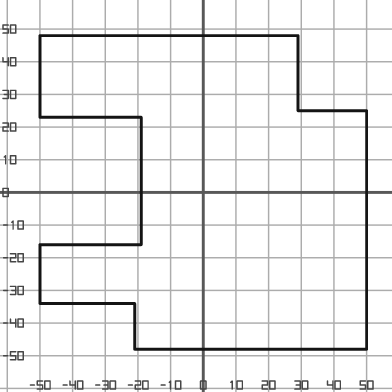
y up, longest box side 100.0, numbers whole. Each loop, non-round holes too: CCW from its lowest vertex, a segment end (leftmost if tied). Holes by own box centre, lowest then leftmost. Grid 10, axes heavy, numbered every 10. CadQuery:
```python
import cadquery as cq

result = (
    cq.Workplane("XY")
    .moveTo(-21.0, -48.0)
    .lineTo(50.0, -48.0)
    .lineTo(50.0, 25.0)
    .lineTo(29.0, 25.0)
    .lineTo(29.0, 48.0)
    .lineTo(-50.0, 48.0)
    .lineTo(-50.0, 23.0)
    .lineTo(-19.0, 23.0)
    .lineTo(-19.0, -16.0)
    .lineTo(-50.0, -16.0)
    .lineTo(-50.0, -34.0)
    .lineTo(-21.0, -34.0)
    .close()
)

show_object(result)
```